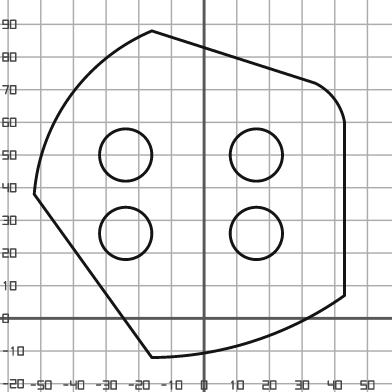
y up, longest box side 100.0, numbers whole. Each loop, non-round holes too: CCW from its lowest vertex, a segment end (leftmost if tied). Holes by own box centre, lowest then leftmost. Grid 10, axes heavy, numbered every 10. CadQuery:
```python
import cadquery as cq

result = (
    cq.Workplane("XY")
    .moveTo(-16.0, -12.0)
    .threePointArc((15.0, -7.0), (43.0, 7.0))
    .lineTo(43.0, 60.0)
    .threePointArc((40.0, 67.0), (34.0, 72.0))
    .lineTo(-16.0, 88.0)
    .threePointArc((-41.0, 68.0), (-52.0, 38.0))
    .close()
    .moveTo(-24.0, 26.0)
    .circle(8.0)
    .moveTo(16.0, 26.0)
    .circle(8.0)
    .moveTo(-24.0, 50.0)
    .circle(8.0)
    .moveTo(16.0, 50.0)
    .circle(8.0)
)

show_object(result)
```